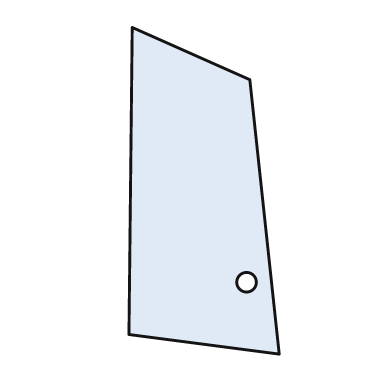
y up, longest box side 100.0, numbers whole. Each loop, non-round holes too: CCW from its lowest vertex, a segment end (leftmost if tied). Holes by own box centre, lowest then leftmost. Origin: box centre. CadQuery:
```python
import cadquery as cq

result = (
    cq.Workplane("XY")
    .moveTo(23.0, -50.0)
    .lineTo(14.0, 34.0)
    .lineTo(-22.0, 50.0)
    .lineTo(-23.0, -44.0)
    .close()
    .moveTo(13.0, -28.0)
    .circle(3.0)
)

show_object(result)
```